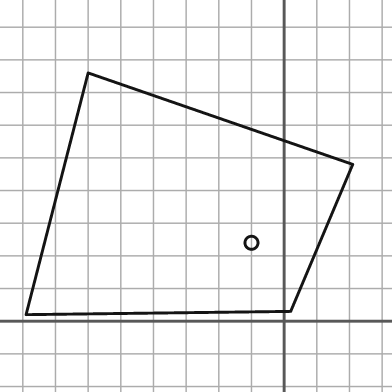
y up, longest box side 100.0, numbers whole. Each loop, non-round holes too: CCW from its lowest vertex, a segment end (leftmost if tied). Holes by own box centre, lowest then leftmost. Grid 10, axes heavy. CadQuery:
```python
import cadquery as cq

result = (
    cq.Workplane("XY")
    .moveTo(-79.0, 2.0)
    .lineTo(2.0, 3.0)
    .lineTo(21.0, 48.0)
    .lineTo(-60.0, 76.0)
    .close()
    .moveTo(-10.0, 24.0)
    .circle(2.0)
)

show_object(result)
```